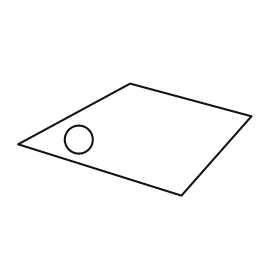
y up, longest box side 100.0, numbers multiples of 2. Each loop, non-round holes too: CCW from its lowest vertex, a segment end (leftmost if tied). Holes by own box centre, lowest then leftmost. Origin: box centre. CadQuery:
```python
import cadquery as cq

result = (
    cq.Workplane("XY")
    .moveTo(20.0, -24.0)
    .lineTo(50.0, 10.0)
    .lineTo(-2.0, 24.0)
    .lineTo(-50.0, -2.0)
    .close()
    .moveTo(-24.0, 0.0)
    .circle(6.0)
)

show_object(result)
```